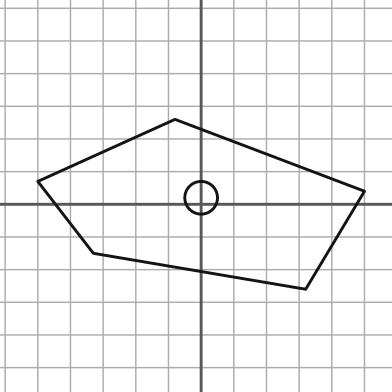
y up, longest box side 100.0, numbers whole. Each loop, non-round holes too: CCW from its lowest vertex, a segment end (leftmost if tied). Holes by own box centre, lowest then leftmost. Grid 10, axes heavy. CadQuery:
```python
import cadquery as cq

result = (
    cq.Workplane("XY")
    .moveTo(32.0, -26.0)
    .lineTo(50.0, 4.0)
    .lineTo(-8.0, 26.0)
    .lineTo(-50.0, 7.0)
    .lineTo(-33.0, -15.0)
    .close()
    .moveTo(0.0, 2.0)
    .circle(5.0)
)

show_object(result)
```